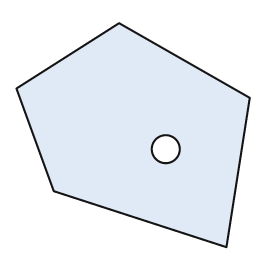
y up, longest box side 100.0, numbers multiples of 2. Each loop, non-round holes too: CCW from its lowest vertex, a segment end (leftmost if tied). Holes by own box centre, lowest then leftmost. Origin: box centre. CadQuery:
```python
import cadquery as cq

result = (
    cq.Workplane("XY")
    .moveTo(40.0, -48.0)
    .lineTo(50.0, 16.0)
    .lineTo(-6.0, 48.0)
    .lineTo(-50.0, 20.0)
    .lineTo(-34.0, -24.0)
    .close()
    .moveTo(14.0, -6.0)
    .circle(6.0)
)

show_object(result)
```